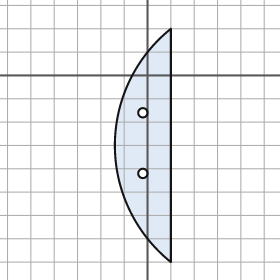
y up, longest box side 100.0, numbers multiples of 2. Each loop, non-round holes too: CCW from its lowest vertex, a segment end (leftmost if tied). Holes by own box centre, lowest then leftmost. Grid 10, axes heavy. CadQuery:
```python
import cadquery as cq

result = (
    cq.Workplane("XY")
    .moveTo(10.0, -80.0)
    .lineTo(10.0, 20.0)
    .threePointArc((-14.0, -30.0), (10.0, -80.0))
    .close()
    .moveTo(-2.0, -42.0)
    .circle(2.0)
    .moveTo(-2.0, -16.0)
    .circle(2.0)
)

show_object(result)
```